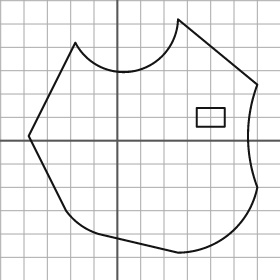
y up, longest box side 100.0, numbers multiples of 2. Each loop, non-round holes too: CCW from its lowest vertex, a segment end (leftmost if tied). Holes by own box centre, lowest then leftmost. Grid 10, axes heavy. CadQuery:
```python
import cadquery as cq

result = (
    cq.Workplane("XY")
    .moveTo(26.0, -48.0)
    .threePointArc((48.0, -40.0), (60.0, -20.0))
    .threePointArc((56.0, 2.0), (60.0, 24.0))
    .lineTo(26.0, 52.0)
    .threePointArc((8.0, 30.0), (-18.0, 42.0))
    .lineTo(-38.0, 2.0)
    .lineTo(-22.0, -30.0)
    .threePointArc((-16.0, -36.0), (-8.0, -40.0))
    .close()
    .moveTo(34.0, 6.0)
    .lineTo(46.0, 6.0)
    .lineTo(46.0, 14.0)
    .lineTo(34.0, 14.0)
    .close()
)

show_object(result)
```